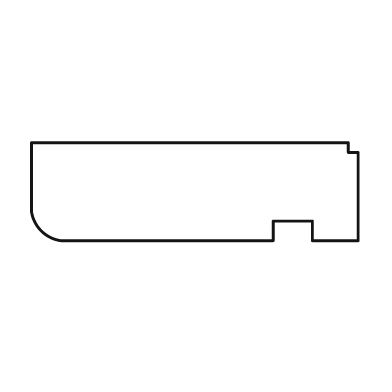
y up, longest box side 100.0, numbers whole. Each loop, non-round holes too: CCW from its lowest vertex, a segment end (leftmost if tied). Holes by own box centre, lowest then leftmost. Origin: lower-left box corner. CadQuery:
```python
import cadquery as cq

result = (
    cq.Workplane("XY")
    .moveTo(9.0, 0.0)
    .lineTo(74.0, 0.0)
    .lineTo(74.0, 6.0)
    .lineTo(86.0, 6.0)
    .lineTo(86.0, 0.0)
    .lineTo(100.0, 0.0)
    .lineTo(100.0, 27.0)
    .lineTo(97.0, 27.0)
    .lineTo(97.0, 30.0)
    .lineTo(0.0, 30.0)
    .lineTo(0.0, 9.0)
    .threePointArc((3.0, 3.0), (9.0, 0.0))
    .close()
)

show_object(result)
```